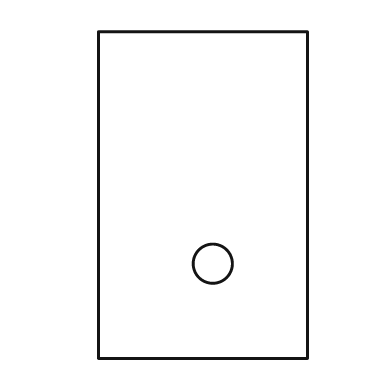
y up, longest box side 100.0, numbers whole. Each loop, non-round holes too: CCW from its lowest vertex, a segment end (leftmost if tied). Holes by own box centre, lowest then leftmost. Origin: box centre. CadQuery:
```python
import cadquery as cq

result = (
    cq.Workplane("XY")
    .moveTo(-32.0, -50.0)
    .lineTo(32.0, -50.0)
    .lineTo(32.0, 50.0)
    .lineTo(-32.0, 50.0)
    .close()
    .moveTo(3.0, -21.0)
    .circle(6.0)
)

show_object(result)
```